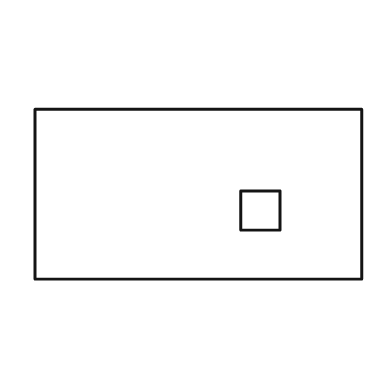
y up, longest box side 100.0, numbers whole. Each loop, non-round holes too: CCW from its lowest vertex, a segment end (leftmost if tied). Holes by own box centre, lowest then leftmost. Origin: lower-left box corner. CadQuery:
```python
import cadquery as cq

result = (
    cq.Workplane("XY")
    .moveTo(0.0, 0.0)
    .lineTo(100.0, 0.0)
    .lineTo(100.0, 52.0)
    .lineTo(0.0, 52.0)
    .close()
    .moveTo(63.0, 15.0)
    .lineTo(75.0, 15.0)
    .lineTo(75.0, 27.0)
    .lineTo(63.0, 27.0)
    .close()
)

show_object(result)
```